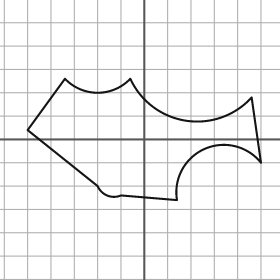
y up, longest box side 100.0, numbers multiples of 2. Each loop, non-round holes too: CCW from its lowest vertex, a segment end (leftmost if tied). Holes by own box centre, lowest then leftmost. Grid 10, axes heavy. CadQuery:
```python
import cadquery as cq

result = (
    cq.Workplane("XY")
    .moveTo(14.0, -26.0)
    .threePointArc((26.0, -4.0), (50.0, -10.0))
    .lineTo(46.0, 18.0)
    .threePointArc((18.0, 8.0), (-6.0, 26.0))
    .threePointArc((-20.0, 20.0), (-34.0, 26.0))
    .lineTo(-50.0, 4.0)
    .lineTo(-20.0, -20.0)
    .threePointArc((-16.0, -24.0), (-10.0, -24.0))
    .close()
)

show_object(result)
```